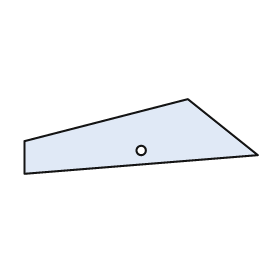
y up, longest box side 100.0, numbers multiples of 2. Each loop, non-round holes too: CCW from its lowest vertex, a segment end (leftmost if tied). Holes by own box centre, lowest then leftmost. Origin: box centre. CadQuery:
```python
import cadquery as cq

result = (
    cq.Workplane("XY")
    .moveTo(-50.0, -16.0)
    .lineTo(50.0, -8.0)
    .lineTo(20.0, 16.0)
    .lineTo(-50.0, -2.0)
    .close()
    .moveTo(0.0, -6.0)
    .circle(2.0)
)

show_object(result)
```